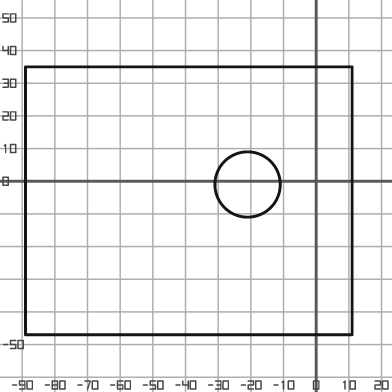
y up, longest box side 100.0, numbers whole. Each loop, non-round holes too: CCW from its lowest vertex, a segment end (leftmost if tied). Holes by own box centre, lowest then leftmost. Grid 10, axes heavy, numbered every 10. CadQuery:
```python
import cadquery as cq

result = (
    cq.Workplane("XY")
    .moveTo(-89.0, -47.0)
    .lineTo(11.0, -47.0)
    .lineTo(11.0, 35.0)
    .lineTo(-89.0, 35.0)
    .close()
    .moveTo(-21.0, -1.0)
    .circle(10.0)
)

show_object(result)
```